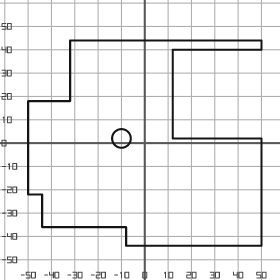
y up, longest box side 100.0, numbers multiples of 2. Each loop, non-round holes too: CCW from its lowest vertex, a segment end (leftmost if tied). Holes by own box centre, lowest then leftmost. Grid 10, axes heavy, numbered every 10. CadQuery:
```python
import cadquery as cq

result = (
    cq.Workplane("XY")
    .moveTo(-8.0, -44.0)
    .lineTo(50.0, -44.0)
    .lineTo(50.0, 2.0)
    .lineTo(12.0, 2.0)
    .lineTo(12.0, 40.0)
    .lineTo(50.0, 40.0)
    .lineTo(50.0, 44.0)
    .lineTo(-32.0, 44.0)
    .lineTo(-32.0, 18.0)
    .lineTo(-50.0, 18.0)
    .lineTo(-50.0, -22.0)
    .lineTo(-44.0, -22.0)
    .lineTo(-44.0, -36.0)
    .lineTo(-8.0, -36.0)
    .close()
    .moveTo(-10.0, 2.0)
    .circle(4.0)
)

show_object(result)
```